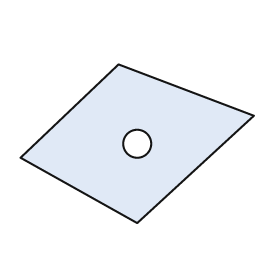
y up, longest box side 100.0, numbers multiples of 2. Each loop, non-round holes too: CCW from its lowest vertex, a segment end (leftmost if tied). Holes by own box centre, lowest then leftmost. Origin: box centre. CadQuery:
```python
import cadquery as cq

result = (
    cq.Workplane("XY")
    .moveTo(0.0, -34.0)
    .lineTo(50.0, 12.0)
    .lineTo(-8.0, 34.0)
    .lineTo(-50.0, -6.0)
    .close()
    .moveTo(0.0, 0.0)
    .circle(6.0)
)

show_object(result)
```